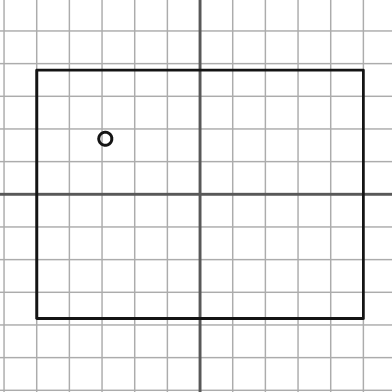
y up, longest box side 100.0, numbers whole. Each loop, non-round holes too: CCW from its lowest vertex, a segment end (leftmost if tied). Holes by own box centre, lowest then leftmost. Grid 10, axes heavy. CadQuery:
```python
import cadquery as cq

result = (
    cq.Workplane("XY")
    .moveTo(-50.0, -38.0)
    .lineTo(50.0, -38.0)
    .lineTo(50.0, 38.0)
    .lineTo(-50.0, 38.0)
    .close()
    .moveTo(-29.0, 17.0)
    .circle(2.0)
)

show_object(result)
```